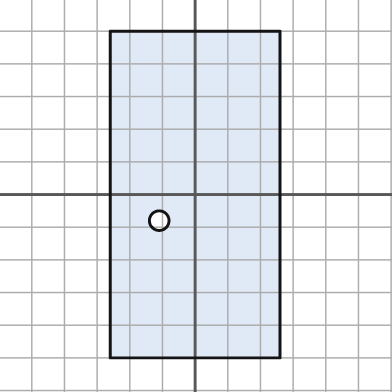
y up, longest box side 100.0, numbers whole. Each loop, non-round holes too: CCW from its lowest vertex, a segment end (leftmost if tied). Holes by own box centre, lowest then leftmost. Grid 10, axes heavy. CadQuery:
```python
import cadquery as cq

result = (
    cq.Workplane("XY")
    .moveTo(-26.0, -50.0)
    .lineTo(26.0, -50.0)
    .lineTo(26.0, 50.0)
    .lineTo(-26.0, 50.0)
    .close()
    .moveTo(-11.0, -8.0)
    .circle(3.0)
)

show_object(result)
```